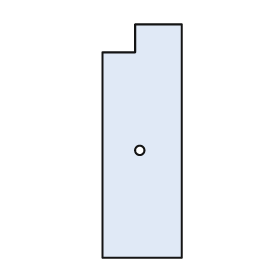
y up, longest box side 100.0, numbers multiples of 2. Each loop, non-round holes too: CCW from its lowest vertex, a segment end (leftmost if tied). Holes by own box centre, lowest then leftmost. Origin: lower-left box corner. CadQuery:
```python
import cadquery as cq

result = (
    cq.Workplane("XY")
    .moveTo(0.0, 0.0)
    .lineTo(34.0, 0.0)
    .lineTo(34.0, 100.0)
    .lineTo(14.0, 100.0)
    .lineTo(14.0, 88.0)
    .lineTo(0.0, 88.0)
    .close()
    .moveTo(16.0, 46.0)
    .circle(2.0)
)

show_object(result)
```